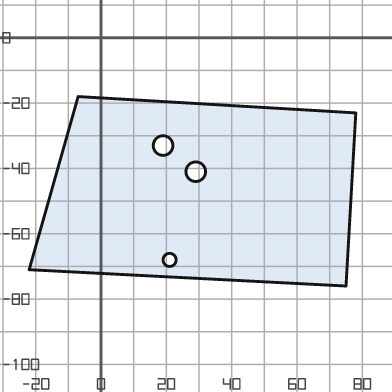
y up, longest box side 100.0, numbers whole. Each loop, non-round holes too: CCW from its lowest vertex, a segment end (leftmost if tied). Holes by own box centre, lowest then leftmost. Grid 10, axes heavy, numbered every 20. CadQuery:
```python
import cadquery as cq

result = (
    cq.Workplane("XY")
    .moveTo(75.0, -76.0)
    .lineTo(78.0, -23.0)
    .lineTo(-7.0, -18.0)
    .lineTo(-22.0, -71.0)
    .close()
    .moveTo(21.0, -68.0)
    .circle(2.0)
    .moveTo(29.0, -41.0)
    .circle(3.0)
    .moveTo(19.0, -33.0)
    .circle(3.0)
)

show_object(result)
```